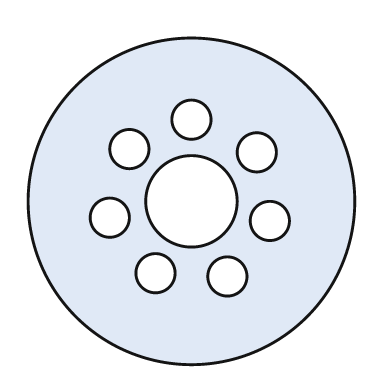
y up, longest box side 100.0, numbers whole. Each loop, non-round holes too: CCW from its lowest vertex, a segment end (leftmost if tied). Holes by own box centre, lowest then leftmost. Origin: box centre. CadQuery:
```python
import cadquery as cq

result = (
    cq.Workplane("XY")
    .moveTo(0.0, 0.0)
    .circle(50.0)
    .moveTo(11.0, -23.0)
    .circle(6.0)
    .moveTo(-11.0, -22.0)
    .circle(6.0)
    .moveTo(24.0, -6.0)
    .circle(6.0)
    .moveTo(-25.0, -5.0)
    .circle(6.0)
    .moveTo(0.0, 0.0)
    .circle(14.0)
    .moveTo(20.0, 15.0)
    .circle(6.0)
    .moveTo(-19.0, 16.0)
    .circle(6.0)
    .moveTo(0.0, 25.0)
    .circle(6.0)
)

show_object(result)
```